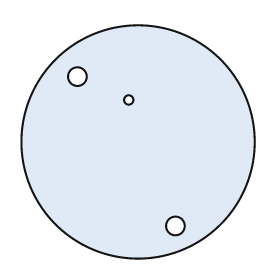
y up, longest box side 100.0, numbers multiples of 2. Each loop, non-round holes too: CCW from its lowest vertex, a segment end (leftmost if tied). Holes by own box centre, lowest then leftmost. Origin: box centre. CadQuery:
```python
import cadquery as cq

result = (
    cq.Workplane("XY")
    .moveTo(0.0, 0.0)
    .circle(50.0)
    .moveTo(16.0, -36.0)
    .circle(4.0)
    .moveTo(-4.0, 18.0)
    .circle(2.0)
    .moveTo(-26.0, 28.0)
    .circle(4.0)
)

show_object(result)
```